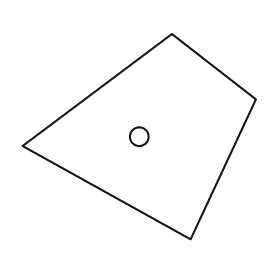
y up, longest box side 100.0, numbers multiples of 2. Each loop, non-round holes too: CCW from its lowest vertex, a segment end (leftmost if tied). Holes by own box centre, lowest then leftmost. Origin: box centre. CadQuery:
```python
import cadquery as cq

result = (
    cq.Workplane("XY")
    .moveTo(22.0, -44.0)
    .lineTo(50.0, 16.0)
    .lineTo(14.0, 44.0)
    .lineTo(-50.0, -4.0)
    .close()
    .moveTo(0.0, 0.0)
    .circle(4.0)
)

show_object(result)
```